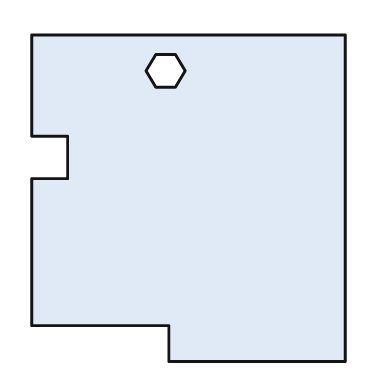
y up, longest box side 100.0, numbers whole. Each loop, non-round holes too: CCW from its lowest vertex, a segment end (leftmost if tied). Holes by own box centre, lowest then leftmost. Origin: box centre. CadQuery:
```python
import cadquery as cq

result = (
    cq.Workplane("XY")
    .moveTo(-6.0, -50.0)
    .lineTo(48.0, -50.0)
    .lineTo(48.0, 50.0)
    .lineTo(-48.0, 50.0)
    .lineTo(-48.0, 19.0)
    .lineTo(-37.0, 19.0)
    .lineTo(-37.0, 6.0)
    .lineTo(-48.0, 6.0)
    .lineTo(-48.0, -39.0)
    .lineTo(-6.0, -39.0)
    .close()
    .moveTo(-10.0, 34.0)
    .lineTo(-4.0, 34.0)
    .lineTo(-1.0, 39.0)
    .lineTo(-4.0, 44.0)
    .lineTo(-10.0, 44.0)
    .lineTo(-13.0, 39.0)
    .close()
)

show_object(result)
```